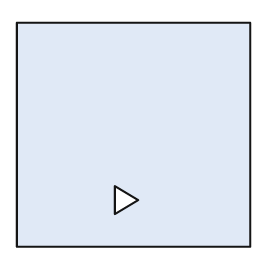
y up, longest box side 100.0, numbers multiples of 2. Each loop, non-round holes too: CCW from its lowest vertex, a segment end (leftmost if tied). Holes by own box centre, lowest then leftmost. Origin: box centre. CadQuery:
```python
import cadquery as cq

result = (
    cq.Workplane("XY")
    .moveTo(-50.0, -48.0)
    .lineTo(50.0, -48.0)
    .lineTo(50.0, 48.0)
    .lineTo(-50.0, 48.0)
    .close()
    .moveTo(-8.0, -34.0)
    .lineTo(2.0, -28.0)
    .lineTo(-8.0, -22.0)
    .close()
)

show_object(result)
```